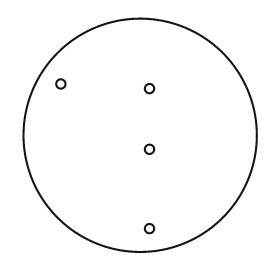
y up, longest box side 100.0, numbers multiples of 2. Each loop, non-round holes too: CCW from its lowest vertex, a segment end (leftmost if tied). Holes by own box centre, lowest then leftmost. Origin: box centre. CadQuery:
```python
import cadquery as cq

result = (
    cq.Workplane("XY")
    .moveTo(0.0, 0.0)
    .circle(50.0)
    .moveTo(4.0, -40.0)
    .circle(2.0)
    .moveTo(4.0, -6.0)
    .circle(2.0)
    .moveTo(4.0, 20.0)
    .circle(2.0)
    .moveTo(-34.0, 22.0)
    .circle(2.0)
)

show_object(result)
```